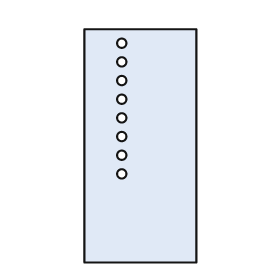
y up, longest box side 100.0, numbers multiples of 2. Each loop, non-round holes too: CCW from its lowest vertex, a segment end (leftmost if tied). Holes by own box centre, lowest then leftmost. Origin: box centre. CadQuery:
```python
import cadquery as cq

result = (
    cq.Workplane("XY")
    .moveTo(-24.0, -50.0)
    .lineTo(24.0, -50.0)
    .lineTo(24.0, 50.0)
    .lineTo(-24.0, 50.0)
    .close()
    .moveTo(-8.0, -12.0)
    .circle(2.0)
    .moveTo(-8.0, -4.0)
    .circle(2.0)
    .moveTo(-8.0, 4.0)
    .circle(2.0)
    .moveTo(-8.0, 12.0)
    .circle(2.0)
    .moveTo(-8.0, 20.0)
    .circle(2.0)
    .moveTo(-8.0, 28.0)
    .circle(2.0)
    .moveTo(-8.0, 36.0)
    .circle(2.0)
    .moveTo(-8.0, 44.0)
    .circle(2.0)
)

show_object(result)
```